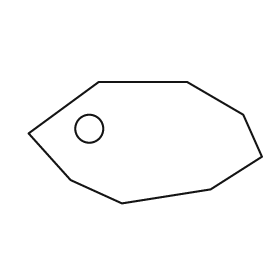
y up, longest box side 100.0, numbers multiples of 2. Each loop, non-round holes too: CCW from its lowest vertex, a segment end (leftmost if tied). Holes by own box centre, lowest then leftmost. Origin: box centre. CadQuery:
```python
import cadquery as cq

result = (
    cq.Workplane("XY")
    .moveTo(-10.0, -26.0)
    .lineTo(28.0, -20.0)
    .lineTo(50.0, -6.0)
    .lineTo(42.0, 12.0)
    .lineTo(18.0, 26.0)
    .lineTo(-20.0, 26.0)
    .lineTo(-50.0, 4.0)
    .lineTo(-32.0, -16.0)
    .close()
    .moveTo(-24.0, 6.0)
    .circle(6.0)
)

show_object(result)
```